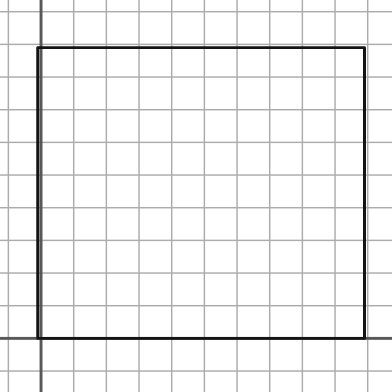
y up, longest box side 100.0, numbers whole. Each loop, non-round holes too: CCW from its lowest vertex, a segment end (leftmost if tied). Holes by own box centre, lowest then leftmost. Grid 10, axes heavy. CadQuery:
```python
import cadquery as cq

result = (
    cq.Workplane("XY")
    .moveTo(-1.0, 0.0)
    .lineTo(99.0, 0.0)
    .lineTo(99.0, 89.0)
    .lineTo(-1.0, 89.0)
    .close()
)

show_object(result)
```